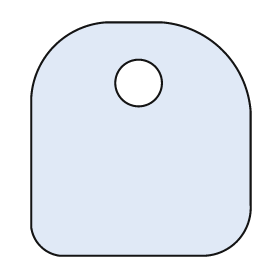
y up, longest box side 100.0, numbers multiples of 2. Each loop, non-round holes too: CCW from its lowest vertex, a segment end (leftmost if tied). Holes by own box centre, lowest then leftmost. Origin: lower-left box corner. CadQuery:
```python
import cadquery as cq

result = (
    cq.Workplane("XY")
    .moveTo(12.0, 0.0)
    .lineTo(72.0, 0.0)
    .threePointArc((88.0, 6.0), (94.0, 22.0))
    .lineTo(94.0, 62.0)
    .threePointArc((82.0, 88.0), (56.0, 100.0))
    .lineTo(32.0, 100.0)
    .threePointArc((10.0, 90.0), (0.0, 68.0))
    .lineTo(0.0, 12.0)
    .threePointArc((4.0, 4.0), (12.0, 0.0))
    .close()
    .moveTo(46.0, 74.0)
    .circle(10.0)
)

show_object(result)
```